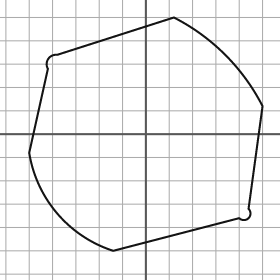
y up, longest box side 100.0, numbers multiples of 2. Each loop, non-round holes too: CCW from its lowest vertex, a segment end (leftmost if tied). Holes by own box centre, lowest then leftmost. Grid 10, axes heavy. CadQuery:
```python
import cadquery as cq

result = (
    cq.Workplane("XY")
    .moveTo(-14.0, -50.0)
    .lineTo(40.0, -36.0)
    .threePointArc((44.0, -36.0), (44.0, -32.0))
    .lineTo(50.0, 12.0)
    .threePointArc((34.0, 34.0), (12.0, 50.0))
    .lineTo(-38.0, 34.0)
    .threePointArc((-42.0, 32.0), (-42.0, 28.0))
    .lineTo(-50.0, -8.0)
    .threePointArc((-38.0, -34.0), (-14.0, -50.0))
    .close()
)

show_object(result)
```